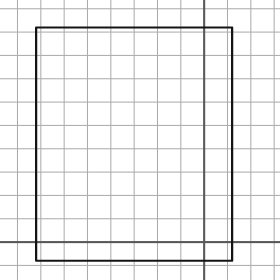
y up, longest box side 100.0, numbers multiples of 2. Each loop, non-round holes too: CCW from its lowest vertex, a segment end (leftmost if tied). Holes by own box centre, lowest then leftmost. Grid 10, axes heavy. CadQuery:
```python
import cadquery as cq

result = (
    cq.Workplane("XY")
    .moveTo(-72.0, -8.0)
    .lineTo(12.0, -8.0)
    .lineTo(12.0, 92.0)
    .lineTo(-72.0, 92.0)
    .close()
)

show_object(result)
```